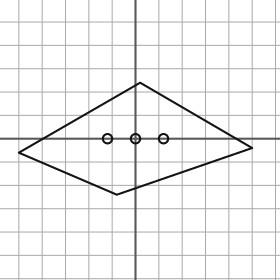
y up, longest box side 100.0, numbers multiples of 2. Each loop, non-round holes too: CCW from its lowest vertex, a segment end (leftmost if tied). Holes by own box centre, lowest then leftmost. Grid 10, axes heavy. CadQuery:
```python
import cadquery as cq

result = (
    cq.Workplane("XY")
    .moveTo(-8.0, -24.0)
    .lineTo(50.0, -4.0)
    .lineTo(2.0, 24.0)
    .lineTo(-50.0, -6.0)
    .close()
    .moveTo(-12.0, 0.0)
    .circle(2.0)
    .moveTo(0.0, 0.0)
    .circle(2.0)
    .moveTo(12.0, 0.0)
    .circle(2.0)
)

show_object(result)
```